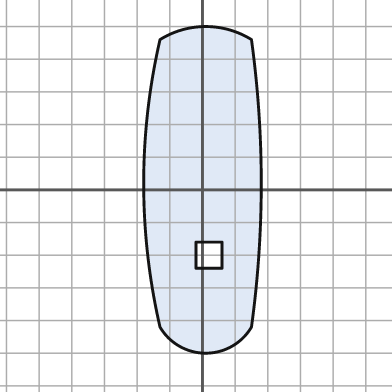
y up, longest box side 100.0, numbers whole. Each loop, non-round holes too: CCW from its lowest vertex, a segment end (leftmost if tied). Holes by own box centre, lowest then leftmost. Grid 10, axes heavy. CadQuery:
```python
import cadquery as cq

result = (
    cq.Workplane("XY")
    .moveTo(-13.0, -42.0)
    .threePointArc((1.0, -50.0), (15.0, -42.0))
    .threePointArc((18.0, 2.0), (15.0, 46.0))
    .threePointArc((1.0, 50.0), (-13.0, 46.0))
    .threePointArc((-18.0, 2.0), (-13.0, -42.0))
    .close()
    .moveTo(-2.0, -24.0)
    .lineTo(6.0, -24.0)
    .lineTo(6.0, -16.0)
    .lineTo(-2.0, -16.0)
    .close()
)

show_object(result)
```